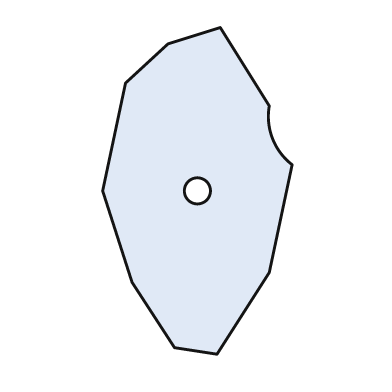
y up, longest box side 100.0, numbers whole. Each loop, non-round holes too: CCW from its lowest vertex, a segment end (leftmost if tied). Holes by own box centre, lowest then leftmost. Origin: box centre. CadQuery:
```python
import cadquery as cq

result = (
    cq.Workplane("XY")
    .moveTo(6.0, -50.0)
    .lineTo(22.0, -25.0)
    .lineTo(29.0, 8.0)
    .threePointArc((23.0, 16.0), (22.0, 26.0))
    .lineTo(7.0, 50.0)
    .lineTo(-9.0, 45.0)
    .lineTo(-22.0, 33.0)
    .lineTo(-29.0, 0.0)
    .lineTo(-20.0, -28.0)
    .lineTo(-7.0, -48.0)
    .close()
    .moveTo(0.0, 0.0)
    .circle(4.0)
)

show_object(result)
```